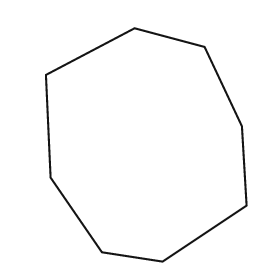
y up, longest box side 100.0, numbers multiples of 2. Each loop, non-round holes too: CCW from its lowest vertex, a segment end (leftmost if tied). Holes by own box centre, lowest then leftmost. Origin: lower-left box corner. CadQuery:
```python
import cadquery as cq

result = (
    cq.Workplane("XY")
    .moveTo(50.0, 0.0)
    .lineTo(86.0, 24.0)
    .lineTo(84.0, 58.0)
    .lineTo(68.0, 92.0)
    .lineTo(38.0, 100.0)
    .lineTo(0.0, 80.0)
    .lineTo(2.0, 36.0)
    .lineTo(24.0, 4.0)
    .close()
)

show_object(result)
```